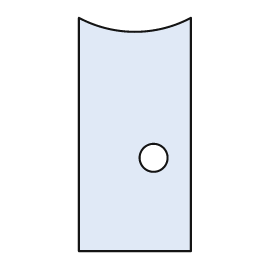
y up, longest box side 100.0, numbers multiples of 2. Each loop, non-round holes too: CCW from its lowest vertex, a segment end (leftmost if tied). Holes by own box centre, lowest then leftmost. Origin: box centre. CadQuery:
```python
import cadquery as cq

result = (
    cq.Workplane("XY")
    .moveTo(-24.0, -50.0)
    .lineTo(24.0, -50.0)
    .lineTo(24.0, 50.0)
    .threePointArc((0.0, 44.0), (-24.0, 50.0))
    .close()
    .moveTo(8.0, -10.0)
    .circle(6.0)
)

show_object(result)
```